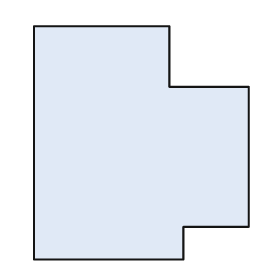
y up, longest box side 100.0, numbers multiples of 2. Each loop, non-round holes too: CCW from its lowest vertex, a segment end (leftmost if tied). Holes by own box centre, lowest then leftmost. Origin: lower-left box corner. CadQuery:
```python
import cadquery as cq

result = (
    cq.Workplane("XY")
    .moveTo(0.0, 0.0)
    .lineTo(64.0, 0.0)
    .lineTo(64.0, 14.0)
    .lineTo(92.0, 14.0)
    .lineTo(92.0, 74.0)
    .lineTo(58.0, 74.0)
    .lineTo(58.0, 100.0)
    .lineTo(0.0, 100.0)
    .close()
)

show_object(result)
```